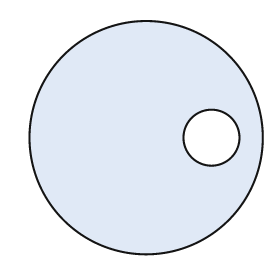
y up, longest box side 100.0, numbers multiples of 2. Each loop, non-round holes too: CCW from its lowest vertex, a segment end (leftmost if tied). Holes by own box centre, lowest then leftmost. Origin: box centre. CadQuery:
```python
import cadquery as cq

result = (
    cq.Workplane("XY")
    .moveTo(0.0, 0.0)
    .circle(50.0)
    .moveTo(28.0, 0.0)
    .circle(12.0)
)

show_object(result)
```